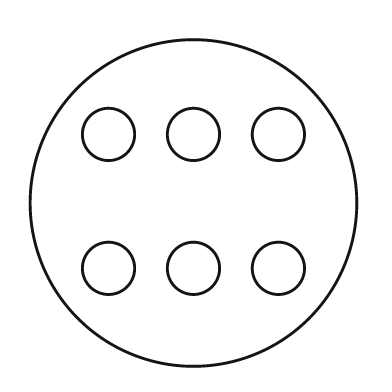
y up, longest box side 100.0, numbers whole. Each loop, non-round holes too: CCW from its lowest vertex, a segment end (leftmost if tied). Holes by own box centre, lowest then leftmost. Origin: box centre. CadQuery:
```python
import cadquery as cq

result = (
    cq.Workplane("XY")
    .moveTo(0.0, 0.0)
    .circle(50.0)
    .moveTo(-26.0, -20.0)
    .circle(8.0)
    .moveTo(0.0, -20.0)
    .circle(8.0)
    .moveTo(26.0, -20.0)
    .circle(8.0)
    .moveTo(-26.0, 21.0)
    .circle(8.0)
    .moveTo(0.0, 21.0)
    .circle(8.0)
    .moveTo(26.0, 21.0)
    .circle(8.0)
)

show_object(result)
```